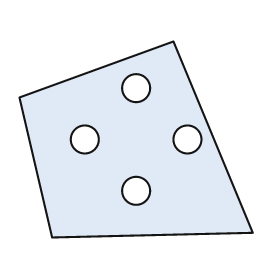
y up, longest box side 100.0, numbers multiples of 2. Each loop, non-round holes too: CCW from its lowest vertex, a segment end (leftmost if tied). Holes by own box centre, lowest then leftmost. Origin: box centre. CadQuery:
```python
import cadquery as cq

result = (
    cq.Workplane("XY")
    .moveTo(-36.0, -42.0)
    .lineTo(50.0, -40.0)
    .lineTo(16.0, 42.0)
    .lineTo(-50.0, 18.0)
    .close()
    .moveTo(0.0, -22.0)
    .circle(6.0)
    .moveTo(-22.0, 0.0)
    .circle(6.0)
    .moveTo(22.0, 0.0)
    .circle(6.0)
    .moveTo(0.0, 22.0)
    .circle(6.0)
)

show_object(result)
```